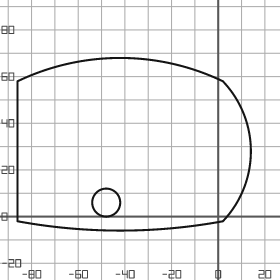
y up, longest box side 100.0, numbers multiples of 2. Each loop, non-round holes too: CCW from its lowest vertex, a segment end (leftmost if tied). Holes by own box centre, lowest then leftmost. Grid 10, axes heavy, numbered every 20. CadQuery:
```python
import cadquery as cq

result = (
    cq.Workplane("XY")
    .moveTo(-86.0, -2.0)
    .threePointArc((-42.0, -6.0), (2.0, -2.0))
    .threePointArc((14.0, 28.0), (2.0, 58.0))
    .threePointArc((-42.0, 68.0), (-86.0, 58.0))
    .close()
    .moveTo(-48.0, 6.0)
    .circle(6.0)
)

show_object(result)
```